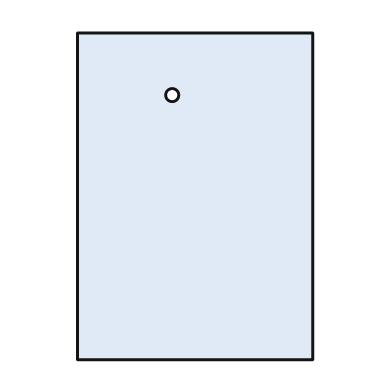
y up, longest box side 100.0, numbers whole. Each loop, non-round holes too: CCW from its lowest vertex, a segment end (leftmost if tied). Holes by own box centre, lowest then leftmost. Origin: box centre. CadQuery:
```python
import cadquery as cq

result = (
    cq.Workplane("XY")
    .moveTo(-36.0, -50.0)
    .lineTo(36.0, -50.0)
    .lineTo(36.0, 50.0)
    .lineTo(-36.0, 50.0)
    .close()
    .moveTo(-7.0, 31.0)
    .circle(2.0)
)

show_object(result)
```